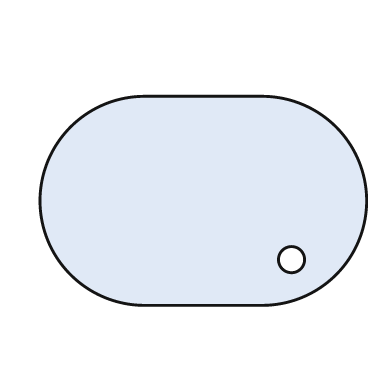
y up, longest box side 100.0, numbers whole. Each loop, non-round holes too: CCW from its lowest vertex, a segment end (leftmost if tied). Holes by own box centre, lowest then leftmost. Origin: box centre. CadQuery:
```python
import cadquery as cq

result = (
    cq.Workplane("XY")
    .moveTo(-18.0, -32.0)
    .lineTo(18.0, -32.0)
    .threePointArc((50.0, 0.0), (18.0, 32.0))
    .lineTo(-18.0, 32.0)
    .threePointArc((-50.0, 0.0), (-18.0, -32.0))
    .close()
    .moveTo(27.0, -18.0)
    .circle(4.0)
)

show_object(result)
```